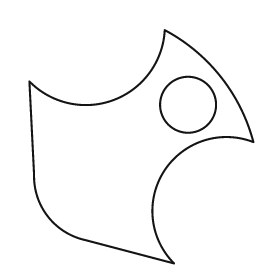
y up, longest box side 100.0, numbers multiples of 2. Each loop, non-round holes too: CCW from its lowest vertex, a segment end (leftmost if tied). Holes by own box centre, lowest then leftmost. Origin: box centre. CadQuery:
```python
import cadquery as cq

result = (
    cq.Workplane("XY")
    .moveTo(14.0, -50.0)
    .threePointArc((10.0, -10.0), (48.0, 2.0))
    .threePointArc((34.0, 30.0), (10.0, 50.0))
    .threePointArc((-12.0, 20.0), (-48.0, 28.0))
    .lineTo(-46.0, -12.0)
    .threePointArc((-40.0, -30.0), (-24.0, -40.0))
    .close()
    .moveTo(20.0, 18.0)
    .circle(12.0)
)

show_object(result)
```